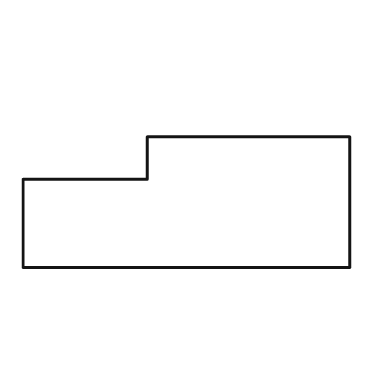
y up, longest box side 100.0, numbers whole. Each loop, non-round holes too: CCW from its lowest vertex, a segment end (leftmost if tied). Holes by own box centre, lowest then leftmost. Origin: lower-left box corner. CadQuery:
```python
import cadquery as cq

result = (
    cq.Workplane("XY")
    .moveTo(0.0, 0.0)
    .lineTo(100.0, 0.0)
    .lineTo(100.0, 40.0)
    .lineTo(38.0, 40.0)
    .lineTo(38.0, 27.0)
    .lineTo(0.0, 27.0)
    .close()
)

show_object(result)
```